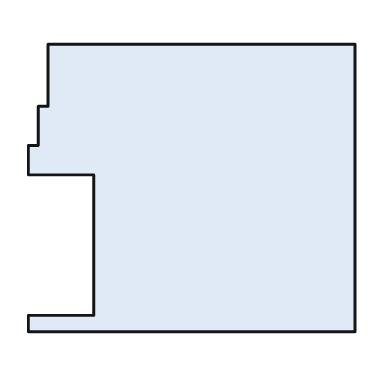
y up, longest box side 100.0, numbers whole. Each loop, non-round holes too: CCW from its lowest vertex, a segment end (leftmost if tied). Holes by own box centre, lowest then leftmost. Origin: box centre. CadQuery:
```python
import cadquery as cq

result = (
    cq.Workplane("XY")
    .moveTo(-50.0, -44.0)
    .lineTo(50.0, -44.0)
    .lineTo(50.0, 44.0)
    .lineTo(-44.0, 44.0)
    .lineTo(-44.0, 25.0)
    .lineTo(-47.0, 25.0)
    .lineTo(-47.0, 13.0)
    .lineTo(-50.0, 13.0)
    .lineTo(-50.0, 4.0)
    .lineTo(-30.0, 4.0)
    .lineTo(-30.0, -39.0)
    .lineTo(-50.0, -39.0)
    .close()
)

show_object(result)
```